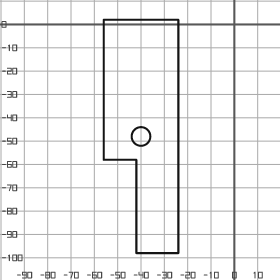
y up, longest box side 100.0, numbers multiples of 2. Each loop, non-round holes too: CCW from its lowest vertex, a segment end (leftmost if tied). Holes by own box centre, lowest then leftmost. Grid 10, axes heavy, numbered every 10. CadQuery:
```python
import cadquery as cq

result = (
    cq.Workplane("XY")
    .moveTo(-42.0, -98.0)
    .lineTo(-24.0, -98.0)
    .lineTo(-24.0, 2.0)
    .lineTo(-56.0, 2.0)
    .lineTo(-56.0, -58.0)
    .lineTo(-42.0, -58.0)
    .close()
    .moveTo(-40.0, -48.0)
    .circle(4.0)
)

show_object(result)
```